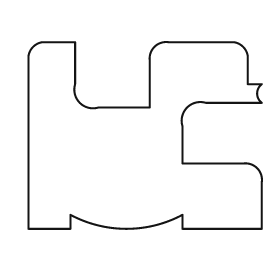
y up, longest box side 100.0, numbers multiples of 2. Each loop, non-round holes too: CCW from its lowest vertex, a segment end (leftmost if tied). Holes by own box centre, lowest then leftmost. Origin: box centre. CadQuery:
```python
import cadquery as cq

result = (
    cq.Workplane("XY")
    .moveTo(-50.0, -40.0)
    .lineTo(-32.0, -40.0)
    .lineTo(-32.0, -34.0)
    .threePointArc((-8.0, -40.0), (16.0, -34.0))
    .lineTo(16.0, -40.0)
    .lineTo(50.0, -40.0)
    .lineTo(50.0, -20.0)
    .threePointArc((48.0, -14.0), (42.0, -12.0))
    .lineTo(16.0, -12.0)
    .lineTo(16.0, 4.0)
    .threePointArc((18.0, 12.0), (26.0, 14.0))
    .lineTo(50.0, 14.0)
    .threePointArc((48.0, 18.0), (50.0, 22.0))
    .lineTo(44.0, 22.0)
    .lineTo(44.0, 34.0)
    .threePointArc((42.0, 38.0), (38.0, 40.0))
    .lineTo(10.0, 40.0)
    .threePointArc((4.0, 38.0), (2.0, 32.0))
    .lineTo(2.0, 12.0)
    .lineTo(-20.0, 12.0)
    .threePointArc((-28.0, 14.0), (-30.0, 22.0))
    .lineTo(-30.0, 40.0)
    .lineTo(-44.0, 40.0)
    .threePointArc((-48.0, 38.0), (-50.0, 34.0))
    .close()
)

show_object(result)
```